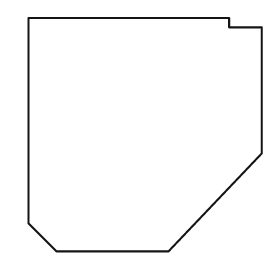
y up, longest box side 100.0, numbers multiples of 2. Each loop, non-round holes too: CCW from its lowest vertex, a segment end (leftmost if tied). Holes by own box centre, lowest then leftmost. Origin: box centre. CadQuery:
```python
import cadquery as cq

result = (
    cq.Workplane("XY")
    .moveTo(-38.0, -50.0)
    .lineTo(10.0, -50.0)
    .lineTo(50.0, -8.0)
    .lineTo(50.0, 46.0)
    .lineTo(36.0, 46.0)
    .lineTo(36.0, 50.0)
    .lineTo(-50.0, 50.0)
    .lineTo(-50.0, -38.0)
    .close()
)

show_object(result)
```